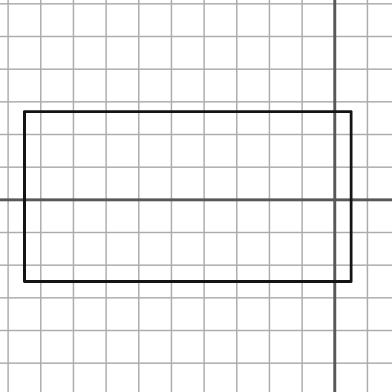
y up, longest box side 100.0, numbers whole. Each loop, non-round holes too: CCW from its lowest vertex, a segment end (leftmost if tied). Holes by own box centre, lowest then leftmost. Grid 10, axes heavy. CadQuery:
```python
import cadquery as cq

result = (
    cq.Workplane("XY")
    .moveTo(-95.0, -25.0)
    .lineTo(5.0, -25.0)
    .lineTo(5.0, 27.0)
    .lineTo(-95.0, 27.0)
    .close()
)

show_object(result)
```